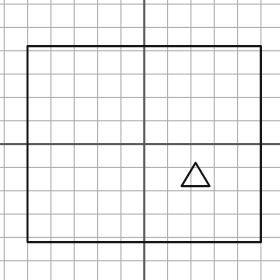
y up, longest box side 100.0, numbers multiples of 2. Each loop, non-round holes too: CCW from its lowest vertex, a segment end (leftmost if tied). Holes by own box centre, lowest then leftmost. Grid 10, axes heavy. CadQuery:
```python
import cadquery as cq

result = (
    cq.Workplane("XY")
    .moveTo(-50.0, -42.0)
    .lineTo(50.0, -42.0)
    .lineTo(50.0, 42.0)
    .lineTo(-50.0, 42.0)
    .close()
    .moveTo(16.0, -18.0)
    .lineTo(28.0, -18.0)
    .lineTo(22.0, -8.0)
    .close()
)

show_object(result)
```